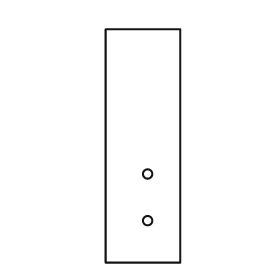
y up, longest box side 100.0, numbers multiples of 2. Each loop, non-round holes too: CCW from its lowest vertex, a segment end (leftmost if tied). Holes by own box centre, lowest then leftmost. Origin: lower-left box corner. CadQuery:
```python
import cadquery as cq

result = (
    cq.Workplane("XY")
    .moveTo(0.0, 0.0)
    .lineTo(32.0, 0.0)
    .lineTo(32.0, 100.0)
    .lineTo(0.0, 100.0)
    .close()
    .moveTo(18.0, 18.0)
    .circle(2.0)
    .moveTo(18.0, 38.0)
    .circle(2.0)
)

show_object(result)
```